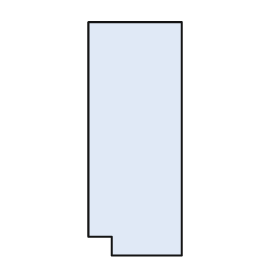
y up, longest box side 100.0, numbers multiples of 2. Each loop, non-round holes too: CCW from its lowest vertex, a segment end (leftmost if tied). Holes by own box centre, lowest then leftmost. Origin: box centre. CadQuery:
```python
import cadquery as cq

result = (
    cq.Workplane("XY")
    .moveTo(-10.0, -50.0)
    .lineTo(20.0, -50.0)
    .lineTo(20.0, 50.0)
    .lineTo(-20.0, 50.0)
    .lineTo(-20.0, -42.0)
    .lineTo(-10.0, -42.0)
    .close()
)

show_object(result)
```